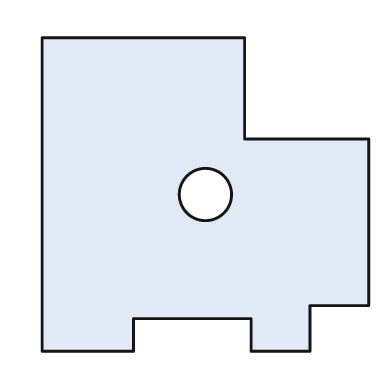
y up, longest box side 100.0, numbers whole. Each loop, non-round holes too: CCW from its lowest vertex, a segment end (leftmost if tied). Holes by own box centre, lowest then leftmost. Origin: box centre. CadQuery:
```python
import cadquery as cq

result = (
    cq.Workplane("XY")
    .moveTo(-50.0, -48.0)
    .lineTo(-22.0, -48.0)
    .lineTo(-22.0, -38.0)
    .lineTo(14.0, -38.0)
    .lineTo(14.0, -48.0)
    .lineTo(32.0, -48.0)
    .lineTo(32.0, -34.0)
    .lineTo(50.0, -34.0)
    .lineTo(50.0, 17.0)
    .lineTo(12.0, 17.0)
    .lineTo(12.0, 48.0)
    .lineTo(-50.0, 48.0)
    .close()
    .moveTo(0.0, 0.0)
    .circle(8.0)
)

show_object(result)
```